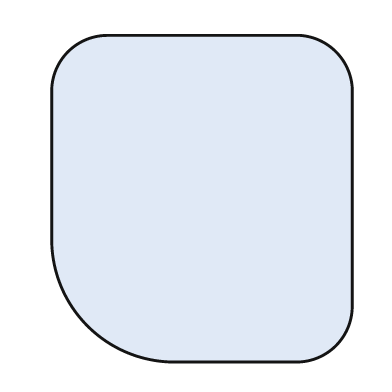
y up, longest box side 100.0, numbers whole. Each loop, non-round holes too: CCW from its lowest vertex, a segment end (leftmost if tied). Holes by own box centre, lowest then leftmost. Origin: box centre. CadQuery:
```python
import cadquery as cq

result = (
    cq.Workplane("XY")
    .moveTo(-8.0, -50.0)
    .lineTo(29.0, -50.0)
    .threePointArc((41.0, -45.0), (46.0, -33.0))
    .lineTo(46.0, 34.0)
    .threePointArc((41.0, 45.0), (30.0, 50.0))
    .lineTo(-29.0, 50.0)
    .threePointArc((-41.0, 45.0), (-46.0, 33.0))
    .lineTo(-46.0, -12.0)
    .threePointArc((-35.0, -39.0), (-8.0, -50.0))
    .close()
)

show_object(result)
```